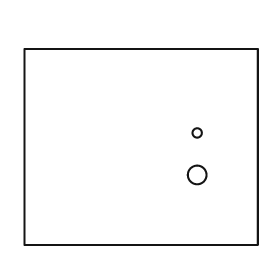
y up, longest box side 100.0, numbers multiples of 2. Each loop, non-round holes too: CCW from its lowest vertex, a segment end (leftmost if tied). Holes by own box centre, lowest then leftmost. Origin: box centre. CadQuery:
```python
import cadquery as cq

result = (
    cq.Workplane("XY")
    .moveTo(-50.0, -42.0)
    .lineTo(50.0, -42.0)
    .lineTo(50.0, 42.0)
    .lineTo(-50.0, 42.0)
    .close()
    .moveTo(24.0, -12.0)
    .circle(4.0)
    .moveTo(24.0, 6.0)
    .circle(2.0)
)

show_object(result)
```